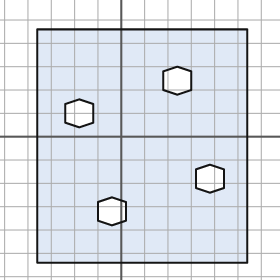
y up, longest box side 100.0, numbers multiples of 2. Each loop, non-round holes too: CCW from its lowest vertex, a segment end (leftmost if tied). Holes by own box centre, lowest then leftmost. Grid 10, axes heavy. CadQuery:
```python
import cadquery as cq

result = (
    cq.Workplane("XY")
    .moveTo(-36.0, -54.0)
    .lineTo(54.0, -54.0)
    .lineTo(54.0, 46.0)
    .lineTo(-36.0, 46.0)
    .close()
    .moveTo(-4.0, -38.0)
    .lineTo(2.0, -36.0)
    .lineTo(2.0, -28.0)
    .lineTo(-4.0, -26.0)
    .lineTo(-10.0, -28.0)
    .lineTo(-10.0, -36.0)
    .close()
    .moveTo(38.0, -24.0)
    .lineTo(44.0, -22.0)
    .lineTo(44.0, -14.0)
    .lineTo(38.0, -12.0)
    .lineTo(32.0, -14.0)
    .lineTo(32.0, -22.0)
    .close()
    .moveTo(-18.0, 4.0)
    .lineTo(-12.0, 6.0)
    .lineTo(-12.0, 14.0)
    .lineTo(-18.0, 16.0)
    .lineTo(-24.0, 14.0)
    .lineTo(-24.0, 6.0)
    .close()
    .moveTo(24.0, 18.0)
    .lineTo(30.0, 20.0)
    .lineTo(30.0, 28.0)
    .lineTo(24.0, 30.0)
    .lineTo(18.0, 28.0)
    .lineTo(18.0, 20.0)
    .close()
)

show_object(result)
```